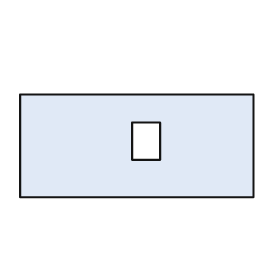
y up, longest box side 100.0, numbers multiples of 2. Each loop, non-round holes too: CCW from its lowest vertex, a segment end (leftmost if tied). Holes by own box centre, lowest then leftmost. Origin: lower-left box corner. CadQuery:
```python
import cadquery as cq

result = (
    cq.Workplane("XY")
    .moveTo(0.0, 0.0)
    .lineTo(100.0, 0.0)
    .lineTo(100.0, 44.0)
    .lineTo(0.0, 44.0)
    .close()
    .moveTo(48.0, 16.0)
    .lineTo(60.0, 16.0)
    .lineTo(60.0, 32.0)
    .lineTo(48.0, 32.0)
    .close()
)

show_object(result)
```